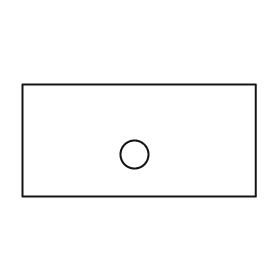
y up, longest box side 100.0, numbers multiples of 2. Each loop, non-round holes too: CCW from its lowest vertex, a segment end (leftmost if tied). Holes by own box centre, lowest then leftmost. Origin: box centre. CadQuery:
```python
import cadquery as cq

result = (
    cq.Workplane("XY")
    .moveTo(-50.0, -24.0)
    .lineTo(50.0, -24.0)
    .lineTo(50.0, 24.0)
    .lineTo(-50.0, 24.0)
    .close()
    .moveTo(-2.0, -6.0)
    .circle(6.0)
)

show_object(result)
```